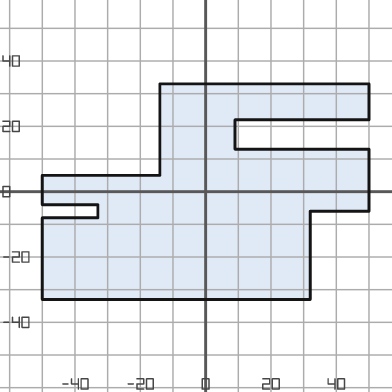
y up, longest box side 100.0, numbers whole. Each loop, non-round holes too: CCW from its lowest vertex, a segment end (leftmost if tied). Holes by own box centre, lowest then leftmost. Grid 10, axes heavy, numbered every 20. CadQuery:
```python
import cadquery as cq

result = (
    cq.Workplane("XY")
    .moveTo(-50.0, -33.0)
    .lineTo(32.0, -33.0)
    .lineTo(32.0, -6.0)
    .lineTo(50.0, -6.0)
    .lineTo(50.0, 13.0)
    .lineTo(9.0, 13.0)
    .lineTo(9.0, 22.0)
    .lineTo(50.0, 22.0)
    .lineTo(50.0, 33.0)
    .lineTo(-14.0, 33.0)
    .lineTo(-14.0, 5.0)
    .lineTo(-50.0, 5.0)
    .lineTo(-50.0, -4.0)
    .lineTo(-33.0, -4.0)
    .lineTo(-33.0, -8.0)
    .lineTo(-50.0, -8.0)
    .close()
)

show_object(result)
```